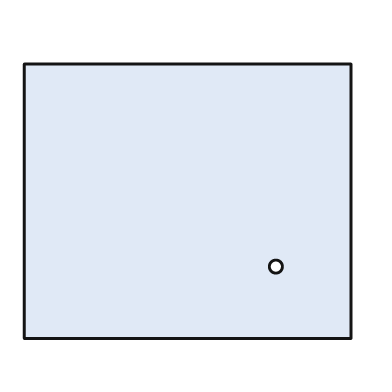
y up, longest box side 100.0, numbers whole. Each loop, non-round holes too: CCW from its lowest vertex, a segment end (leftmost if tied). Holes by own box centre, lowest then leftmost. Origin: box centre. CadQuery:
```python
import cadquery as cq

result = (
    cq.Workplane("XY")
    .moveTo(-50.0, -42.0)
    .lineTo(50.0, -42.0)
    .lineTo(50.0, 42.0)
    .lineTo(-50.0, 42.0)
    .close()
    .moveTo(27.0, -20.0)
    .circle(2.0)
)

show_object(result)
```